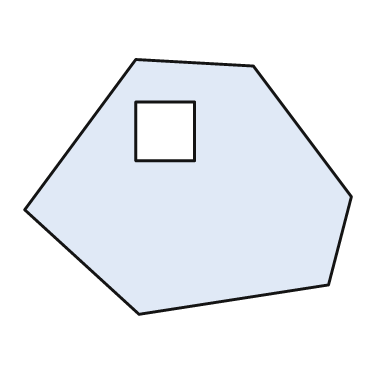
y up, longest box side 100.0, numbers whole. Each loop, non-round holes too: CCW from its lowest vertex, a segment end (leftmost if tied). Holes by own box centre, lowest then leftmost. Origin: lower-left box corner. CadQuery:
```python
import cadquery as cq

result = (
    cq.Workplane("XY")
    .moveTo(35.0, 0.0)
    .lineTo(93.0, 9.0)
    .lineTo(100.0, 36.0)
    .lineTo(70.0, 76.0)
    .lineTo(34.0, 78.0)
    .lineTo(0.0, 32.0)
    .close()
    .moveTo(34.0, 47.0)
    .lineTo(52.0, 47.0)
    .lineTo(52.0, 65.0)
    .lineTo(34.0, 65.0)
    .close()
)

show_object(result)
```